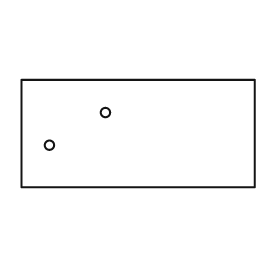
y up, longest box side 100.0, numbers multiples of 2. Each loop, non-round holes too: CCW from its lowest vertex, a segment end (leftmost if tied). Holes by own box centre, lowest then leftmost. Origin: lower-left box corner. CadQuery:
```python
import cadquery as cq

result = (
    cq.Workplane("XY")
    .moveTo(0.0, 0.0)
    .lineTo(100.0, 0.0)
    .lineTo(100.0, 46.0)
    .lineTo(0.0, 46.0)
    .close()
    .moveTo(12.0, 18.0)
    .circle(2.0)
    .moveTo(36.0, 32.0)
    .circle(2.0)
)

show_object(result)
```